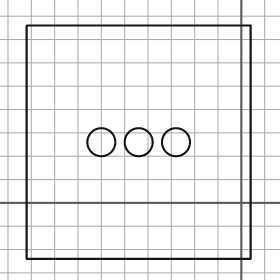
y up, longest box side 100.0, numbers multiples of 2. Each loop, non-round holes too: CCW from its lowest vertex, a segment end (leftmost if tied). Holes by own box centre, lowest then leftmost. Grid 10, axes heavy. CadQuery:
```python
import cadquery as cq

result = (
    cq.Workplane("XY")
    .moveTo(-92.0, -24.0)
    .lineTo(4.0, -24.0)
    .lineTo(4.0, 76.0)
    .lineTo(-92.0, 76.0)
    .close()
    .moveTo(-60.0, 26.0)
    .circle(6.0)
    .moveTo(-44.0, 26.0)
    .circle(6.0)
    .moveTo(-28.0, 26.0)
    .circle(6.0)
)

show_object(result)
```